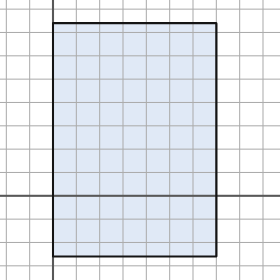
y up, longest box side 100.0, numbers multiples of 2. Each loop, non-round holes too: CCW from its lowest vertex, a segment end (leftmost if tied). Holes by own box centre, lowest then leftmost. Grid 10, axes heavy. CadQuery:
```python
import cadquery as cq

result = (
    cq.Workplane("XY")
    .moveTo(0.0, -26.0)
    .lineTo(70.0, -26.0)
    .lineTo(70.0, 74.0)
    .lineTo(0.0, 74.0)
    .close()
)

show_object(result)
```